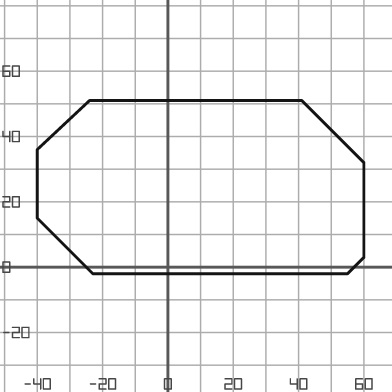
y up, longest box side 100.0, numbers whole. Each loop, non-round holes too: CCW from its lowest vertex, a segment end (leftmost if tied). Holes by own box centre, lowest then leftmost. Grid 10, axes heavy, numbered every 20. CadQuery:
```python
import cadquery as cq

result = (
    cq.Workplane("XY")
    .moveTo(-23.0, -2.0)
    .lineTo(55.0, -2.0)
    .lineTo(60.0, 3.0)
    .lineTo(60.0, 32.0)
    .lineTo(41.0, 51.0)
    .lineTo(-24.0, 51.0)
    .lineTo(-40.0, 36.0)
    .lineTo(-40.0, 15.0)
    .close()
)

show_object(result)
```